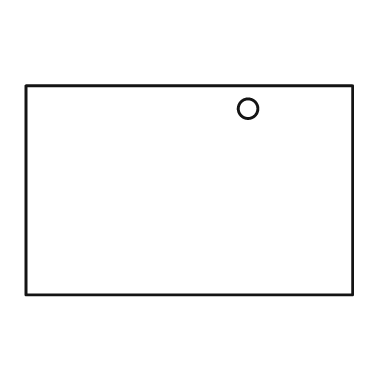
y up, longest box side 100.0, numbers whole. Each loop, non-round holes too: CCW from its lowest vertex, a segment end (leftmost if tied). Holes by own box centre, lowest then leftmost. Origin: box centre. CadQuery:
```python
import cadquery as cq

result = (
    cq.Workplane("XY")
    .moveTo(-50.0, -32.0)
    .lineTo(50.0, -32.0)
    .lineTo(50.0, 32.0)
    .lineTo(-50.0, 32.0)
    .close()
    .moveTo(18.0, 25.0)
    .circle(3.0)
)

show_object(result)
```